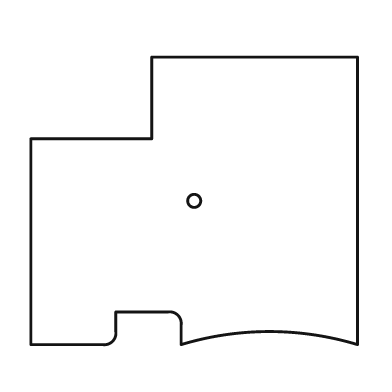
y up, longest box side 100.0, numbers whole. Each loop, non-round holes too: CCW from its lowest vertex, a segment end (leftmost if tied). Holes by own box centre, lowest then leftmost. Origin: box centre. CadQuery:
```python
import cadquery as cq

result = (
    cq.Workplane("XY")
    .moveTo(-50.0, -44.0)
    .lineTo(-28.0, -44.0)
    .threePointArc((-25.0, -43.0), (-24.0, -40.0))
    .lineTo(-24.0, -34.0)
    .lineTo(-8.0, -34.0)
    .threePointArc((-5.0, -35.0), (-4.0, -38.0))
    .lineTo(-4.0, -44.0)
    .threePointArc((23.0, -40.0), (50.0, -44.0))
    .lineTo(50.0, 44.0)
    .lineTo(-13.0, 44.0)
    .lineTo(-13.0, 19.0)
    .lineTo(-50.0, 19.0)
    .close()
    .moveTo(0.0, 0.0)
    .circle(2.0)
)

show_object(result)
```